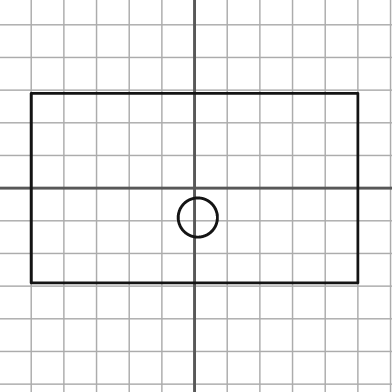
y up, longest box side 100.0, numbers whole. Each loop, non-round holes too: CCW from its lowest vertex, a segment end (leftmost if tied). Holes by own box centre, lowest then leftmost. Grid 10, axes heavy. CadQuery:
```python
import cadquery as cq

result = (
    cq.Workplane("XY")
    .moveTo(-50.0, -29.0)
    .lineTo(50.0, -29.0)
    .lineTo(50.0, 29.0)
    .lineTo(-50.0, 29.0)
    .close()
    .moveTo(1.0, -9.0)
    .circle(6.0)
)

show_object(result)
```